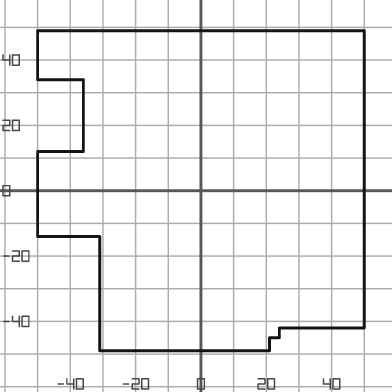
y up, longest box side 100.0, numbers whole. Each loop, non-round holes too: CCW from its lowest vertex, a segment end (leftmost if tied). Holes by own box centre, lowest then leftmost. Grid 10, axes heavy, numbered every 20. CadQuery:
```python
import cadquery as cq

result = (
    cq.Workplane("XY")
    .moveTo(-31.0, -49.0)
    .lineTo(21.0, -49.0)
    .lineTo(21.0, -45.0)
    .lineTo(24.0, -45.0)
    .lineTo(24.0, -42.0)
    .lineTo(50.0, -42.0)
    .lineTo(50.0, 49.0)
    .lineTo(-50.0, 49.0)
    .lineTo(-50.0, 34.0)
    .lineTo(-36.0, 34.0)
    .lineTo(-36.0, 12.0)
    .lineTo(-50.0, 12.0)
    .lineTo(-50.0, -14.0)
    .lineTo(-31.0, -14.0)
    .close()
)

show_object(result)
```